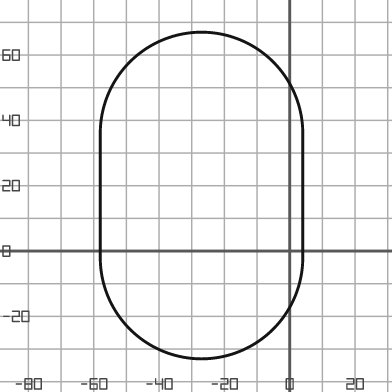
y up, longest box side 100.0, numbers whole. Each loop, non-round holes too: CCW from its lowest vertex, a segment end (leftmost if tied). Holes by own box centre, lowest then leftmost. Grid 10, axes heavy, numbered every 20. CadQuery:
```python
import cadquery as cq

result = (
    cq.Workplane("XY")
    .moveTo(-58.0, -2.0)
    .threePointArc((-27.0, -33.0), (4.0, -2.0))
    .lineTo(4.0, 36.0)
    .threePointArc((-27.0, 67.0), (-58.0, 36.0))
    .close()
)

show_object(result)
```